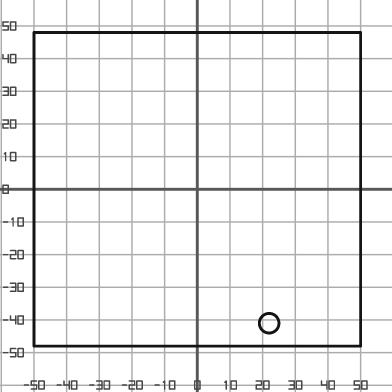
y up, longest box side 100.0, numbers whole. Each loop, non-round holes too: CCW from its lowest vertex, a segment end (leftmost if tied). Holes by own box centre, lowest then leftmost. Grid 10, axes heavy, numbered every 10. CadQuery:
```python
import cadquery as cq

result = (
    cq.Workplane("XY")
    .moveTo(-50.0, -48.0)
    .lineTo(50.0, -48.0)
    .lineTo(50.0, 48.0)
    .lineTo(-50.0, 48.0)
    .close()
    .moveTo(22.0, -41.0)
    .circle(3.0)
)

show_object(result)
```